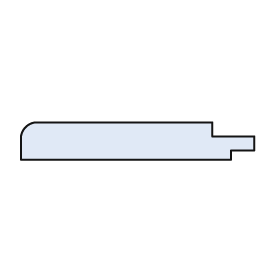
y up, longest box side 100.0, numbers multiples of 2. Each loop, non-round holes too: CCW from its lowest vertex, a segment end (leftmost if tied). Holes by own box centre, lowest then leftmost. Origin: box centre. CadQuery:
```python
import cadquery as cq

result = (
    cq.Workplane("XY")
    .moveTo(-50.0, -8.0)
    .lineTo(40.0, -8.0)
    .lineTo(40.0, -4.0)
    .lineTo(50.0, -4.0)
    .lineTo(50.0, 2.0)
    .lineTo(32.0, 2.0)
    .lineTo(32.0, 8.0)
    .lineTo(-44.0, 8.0)
    .threePointArc((-48.0, 6.0), (-50.0, 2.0))
    .close()
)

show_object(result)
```